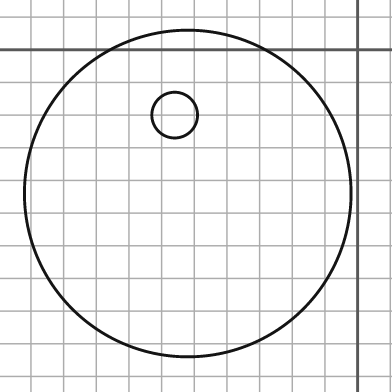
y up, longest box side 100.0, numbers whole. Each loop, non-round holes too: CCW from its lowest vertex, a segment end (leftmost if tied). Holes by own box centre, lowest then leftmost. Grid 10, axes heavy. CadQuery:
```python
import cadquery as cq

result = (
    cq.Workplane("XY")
    .moveTo(-52.0, -44.0)
    .circle(50.0)
    .moveTo(-56.0, -20.0)
    .circle(7.0)
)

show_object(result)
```